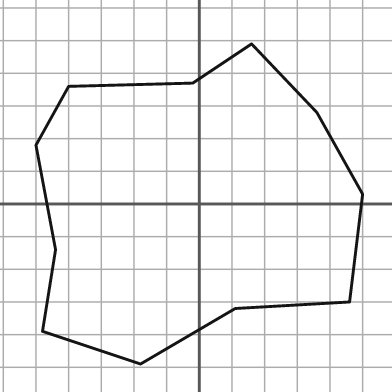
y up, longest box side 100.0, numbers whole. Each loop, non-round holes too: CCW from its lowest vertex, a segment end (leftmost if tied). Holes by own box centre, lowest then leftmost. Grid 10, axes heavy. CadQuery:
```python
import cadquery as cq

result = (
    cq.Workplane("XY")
    .moveTo(-18.0, -49.0)
    .lineTo(11.0, -32.0)
    .lineTo(46.0, -30.0)
    .lineTo(50.0, 3.0)
    .lineTo(36.0, 28.0)
    .lineTo(16.0, 49.0)
    .lineTo(-2.0, 37.0)
    .lineTo(-40.0, 36.0)
    .lineTo(-50.0, 18.0)
    .lineTo(-44.0, -14.0)
    .lineTo(-48.0, -39.0)
    .close()
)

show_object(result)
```